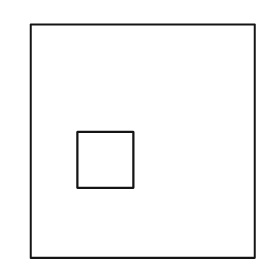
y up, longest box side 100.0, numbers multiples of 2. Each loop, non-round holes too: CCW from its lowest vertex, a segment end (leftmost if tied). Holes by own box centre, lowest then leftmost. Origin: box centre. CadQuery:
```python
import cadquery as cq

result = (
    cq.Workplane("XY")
    .moveTo(-48.0, -50.0)
    .lineTo(48.0, -50.0)
    .lineTo(48.0, 50.0)
    .lineTo(-48.0, 50.0)
    .close()
    .moveTo(-28.0, -20.0)
    .lineTo(-4.0, -20.0)
    .lineTo(-4.0, 4.0)
    .lineTo(-28.0, 4.0)
    .close()
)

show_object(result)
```